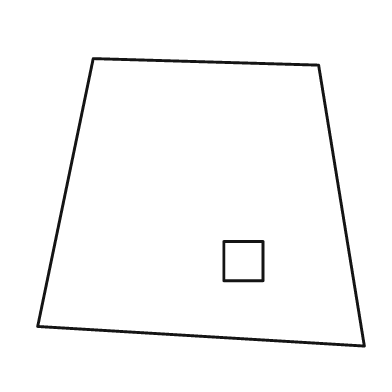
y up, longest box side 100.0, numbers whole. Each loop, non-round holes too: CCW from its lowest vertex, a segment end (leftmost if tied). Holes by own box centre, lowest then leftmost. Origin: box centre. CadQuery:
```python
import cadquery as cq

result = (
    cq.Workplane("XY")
    .moveTo(50.0, -44.0)
    .lineTo(36.0, 42.0)
    .lineTo(-33.0, 44.0)
    .lineTo(-50.0, -38.0)
    .close()
    .moveTo(7.0, -24.0)
    .lineTo(19.0, -24.0)
    .lineTo(19.0, -12.0)
    .lineTo(7.0, -12.0)
    .close()
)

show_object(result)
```